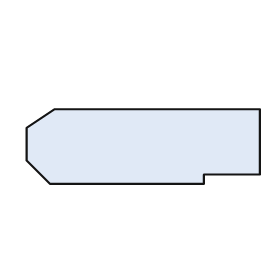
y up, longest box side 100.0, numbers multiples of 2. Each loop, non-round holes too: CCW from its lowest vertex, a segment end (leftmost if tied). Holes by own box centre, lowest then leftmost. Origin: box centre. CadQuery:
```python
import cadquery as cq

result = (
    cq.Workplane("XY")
    .moveTo(-40.0, -16.0)
    .lineTo(26.0, -16.0)
    .lineTo(26.0, -12.0)
    .lineTo(50.0, -12.0)
    .lineTo(50.0, 16.0)
    .lineTo(-38.0, 16.0)
    .lineTo(-50.0, 8.0)
    .lineTo(-50.0, -6.0)
    .close()
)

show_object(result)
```